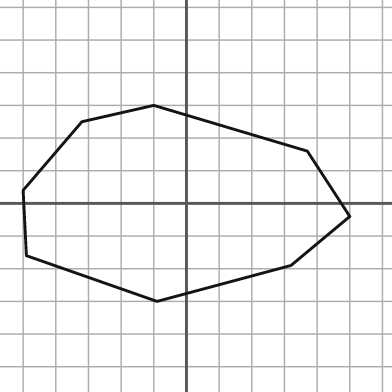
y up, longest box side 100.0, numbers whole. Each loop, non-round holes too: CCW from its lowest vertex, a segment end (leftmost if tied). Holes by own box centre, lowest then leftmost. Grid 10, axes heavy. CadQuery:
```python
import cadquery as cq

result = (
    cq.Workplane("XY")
    .moveTo(-9.0, -30.0)
    .lineTo(32.0, -19.0)
    .lineTo(50.0, -4.0)
    .lineTo(37.0, 16.0)
    .lineTo(-10.0, 30.0)
    .lineTo(-32.0, 25.0)
    .lineTo(-50.0, 4.0)
    .lineTo(-49.0, -16.0)
    .close()
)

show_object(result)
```